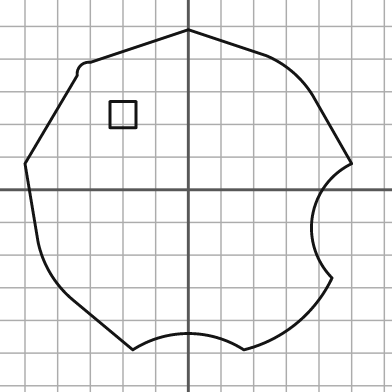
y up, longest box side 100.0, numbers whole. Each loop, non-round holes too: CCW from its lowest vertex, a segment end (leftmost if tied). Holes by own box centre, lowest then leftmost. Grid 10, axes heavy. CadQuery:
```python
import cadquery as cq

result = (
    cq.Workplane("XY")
    .moveTo(-17.0, -49.0)
    .threePointArc((0.0, -44.0), (17.0, -49.0))
    .threePointArc((33.0, -41.0), (44.0, -27.0))
    .threePointArc((38.0, -8.0), (50.0, 8.0))
    .lineTo(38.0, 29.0)
    .threePointArc((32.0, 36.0), (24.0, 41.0))
    .lineTo(0.0, 49.0)
    .lineTo(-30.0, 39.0)
    .threePointArc((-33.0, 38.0), (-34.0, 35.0))
    .lineTo(-50.0, 8.0)
    .lineTo(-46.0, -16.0)
    .threePointArc((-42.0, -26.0), (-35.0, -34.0))
    .close()
    .moveTo(-24.0, 19.0)
    .lineTo(-16.0, 19.0)
    .lineTo(-16.0, 27.0)
    .lineTo(-24.0, 27.0)
    .close()
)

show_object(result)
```